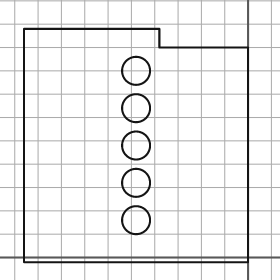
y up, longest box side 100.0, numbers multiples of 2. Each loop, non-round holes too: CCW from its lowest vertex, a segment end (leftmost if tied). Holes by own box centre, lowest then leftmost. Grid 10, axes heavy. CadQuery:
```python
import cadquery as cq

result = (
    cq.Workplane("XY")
    .moveTo(-96.0, -2.0)
    .lineTo(0.0, -2.0)
    .lineTo(0.0, 90.0)
    .lineTo(-38.0, 90.0)
    .lineTo(-38.0, 98.0)
    .lineTo(-96.0, 98.0)
    .close()
    .moveTo(-48.0, 16.0)
    .circle(6.0)
    .moveTo(-48.0, 32.0)
    .circle(6.0)
    .moveTo(-48.0, 48.0)
    .circle(6.0)
    .moveTo(-48.0, 64.0)
    .circle(6.0)
    .moveTo(-48.0, 80.0)
    .circle(6.0)
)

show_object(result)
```